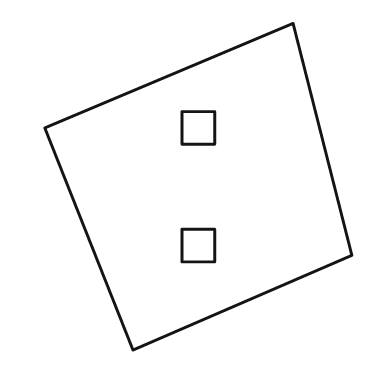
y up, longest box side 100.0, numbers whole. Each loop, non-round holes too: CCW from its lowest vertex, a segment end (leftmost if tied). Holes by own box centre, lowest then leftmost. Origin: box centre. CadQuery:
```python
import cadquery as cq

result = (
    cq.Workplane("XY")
    .moveTo(-20.0, -50.0)
    .lineTo(47.0, -21.0)
    .lineTo(29.0, 50.0)
    .lineTo(-47.0, 18.0)
    .close()
    .moveTo(-5.0, -23.0)
    .lineTo(5.0, -23.0)
    .lineTo(5.0, -13.0)
    .lineTo(-5.0, -13.0)
    .close()
    .moveTo(-5.0, 13.0)
    .lineTo(5.0, 13.0)
    .lineTo(5.0, 23.0)
    .lineTo(-5.0, 23.0)
    .close()
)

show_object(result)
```